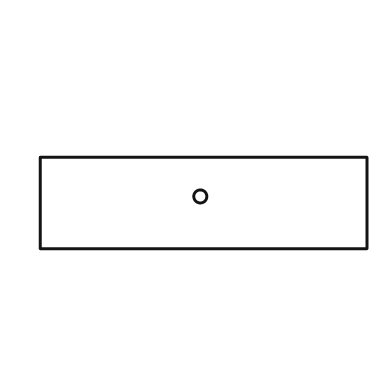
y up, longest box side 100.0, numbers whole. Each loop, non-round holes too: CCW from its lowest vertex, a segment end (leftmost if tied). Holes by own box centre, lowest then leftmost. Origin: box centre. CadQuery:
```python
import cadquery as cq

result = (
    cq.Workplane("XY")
    .moveTo(-50.0, -14.0)
    .lineTo(50.0, -14.0)
    .lineTo(50.0, 14.0)
    .lineTo(-50.0, 14.0)
    .close()
    .moveTo(-1.0, 2.0)
    .circle(2.0)
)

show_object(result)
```